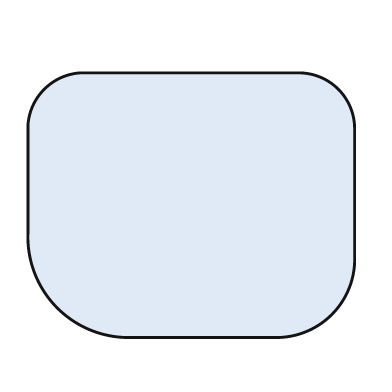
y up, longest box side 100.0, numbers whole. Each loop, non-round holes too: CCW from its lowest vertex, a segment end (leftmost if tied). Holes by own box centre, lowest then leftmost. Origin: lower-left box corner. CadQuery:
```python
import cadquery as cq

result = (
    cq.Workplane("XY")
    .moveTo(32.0, 0.0)
    .lineTo(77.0, 0.0)
    .threePointArc((93.0, 7.0), (100.0, 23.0))
    .lineTo(100.0, 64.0)
    .threePointArc((95.0, 76.0), (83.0, 81.0))
    .lineTo(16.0, 81.0)
    .threePointArc((5.0, 76.0), (0.0, 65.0))
    .lineTo(0.0, 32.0)
    .threePointArc((9.0, 9.0), (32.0, 0.0))
    .close()
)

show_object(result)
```